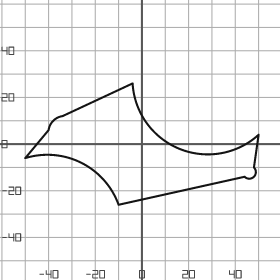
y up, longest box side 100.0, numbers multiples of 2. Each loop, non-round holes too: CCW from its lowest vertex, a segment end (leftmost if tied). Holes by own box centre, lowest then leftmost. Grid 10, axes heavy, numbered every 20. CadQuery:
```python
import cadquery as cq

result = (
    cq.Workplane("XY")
    .moveTo(-10.0, -26.0)
    .lineTo(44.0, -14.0)
    .threePointArc((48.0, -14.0), (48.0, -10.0))
    .lineTo(50.0, 4.0)
    .threePointArc((16.0, -2.0), (-4.0, 26.0))
    .lineTo(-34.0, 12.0)
    .threePointArc((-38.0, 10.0), (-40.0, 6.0))
    .lineTo(-50.0, -6.0)
    .threePointArc((-26.0, -8.0), (-10.0, -26.0))
    .close()
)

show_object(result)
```